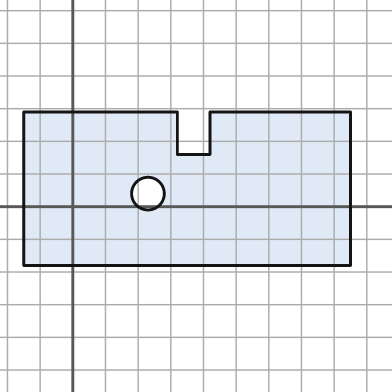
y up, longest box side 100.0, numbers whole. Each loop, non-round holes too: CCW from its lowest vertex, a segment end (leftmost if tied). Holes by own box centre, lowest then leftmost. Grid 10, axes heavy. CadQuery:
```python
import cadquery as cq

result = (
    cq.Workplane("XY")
    .moveTo(-15.0, -18.0)
    .lineTo(85.0, -18.0)
    .lineTo(85.0, 29.0)
    .lineTo(42.0, 29.0)
    .lineTo(42.0, 16.0)
    .lineTo(32.0, 16.0)
    .lineTo(32.0, 29.0)
    .lineTo(-15.0, 29.0)
    .close()
    .moveTo(23.0, 4.0)
    .circle(5.0)
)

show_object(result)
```